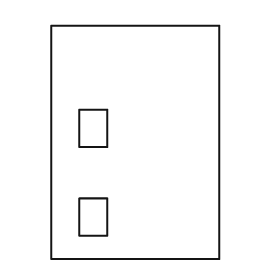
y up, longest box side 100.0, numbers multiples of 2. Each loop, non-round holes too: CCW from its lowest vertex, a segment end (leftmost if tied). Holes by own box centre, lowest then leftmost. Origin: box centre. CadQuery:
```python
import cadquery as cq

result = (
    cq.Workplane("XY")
    .moveTo(-36.0, -50.0)
    .lineTo(36.0, -50.0)
    .lineTo(36.0, 50.0)
    .lineTo(-36.0, 50.0)
    .close()
    .moveTo(-24.0, -40.0)
    .lineTo(-12.0, -40.0)
    .lineTo(-12.0, -24.0)
    .lineTo(-24.0, -24.0)
    .close()
    .moveTo(-24.0, -2.0)
    .lineTo(-12.0, -2.0)
    .lineTo(-12.0, 14.0)
    .lineTo(-24.0, 14.0)
    .close()
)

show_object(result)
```